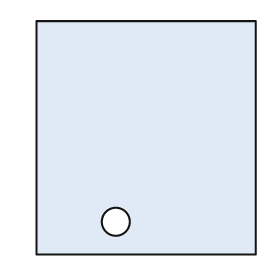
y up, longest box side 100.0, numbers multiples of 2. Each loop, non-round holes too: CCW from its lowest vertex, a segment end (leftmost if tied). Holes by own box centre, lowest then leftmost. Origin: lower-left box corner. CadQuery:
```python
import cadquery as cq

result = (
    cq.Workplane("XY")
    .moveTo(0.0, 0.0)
    .lineTo(94.0, 0.0)
    .lineTo(94.0, 100.0)
    .lineTo(0.0, 100.0)
    .close()
    .moveTo(34.0, 14.0)
    .circle(6.0)
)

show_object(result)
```